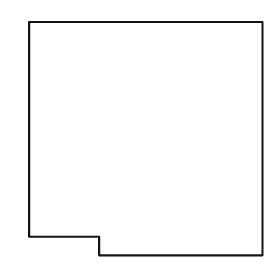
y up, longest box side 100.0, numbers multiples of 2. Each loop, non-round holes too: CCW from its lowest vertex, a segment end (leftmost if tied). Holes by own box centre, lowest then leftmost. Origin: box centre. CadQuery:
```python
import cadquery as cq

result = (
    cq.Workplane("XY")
    .moveTo(-20.0, -50.0)
    .lineTo(50.0, -50.0)
    .lineTo(50.0, 50.0)
    .lineTo(-50.0, 50.0)
    .lineTo(-50.0, -42.0)
    .lineTo(-20.0, -42.0)
    .close()
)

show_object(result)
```